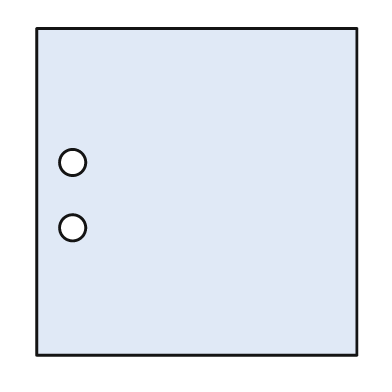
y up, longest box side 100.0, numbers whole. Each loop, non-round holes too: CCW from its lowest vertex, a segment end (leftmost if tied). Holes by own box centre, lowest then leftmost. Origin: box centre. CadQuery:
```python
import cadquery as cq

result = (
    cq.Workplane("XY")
    .moveTo(-49.0, -50.0)
    .lineTo(49.0, -50.0)
    .lineTo(49.0, 50.0)
    .lineTo(-49.0, 50.0)
    .close()
    .moveTo(-38.0, -11.0)
    .circle(4.0)
    .moveTo(-38.0, 9.0)
    .circle(4.0)
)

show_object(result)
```